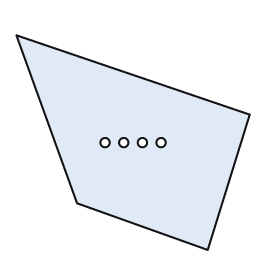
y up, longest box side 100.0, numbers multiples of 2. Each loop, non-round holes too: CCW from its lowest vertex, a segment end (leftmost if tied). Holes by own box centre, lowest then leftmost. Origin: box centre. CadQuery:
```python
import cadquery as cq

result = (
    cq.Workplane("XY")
    .moveTo(32.0, -46.0)
    .lineTo(50.0, 12.0)
    .lineTo(-50.0, 46.0)
    .lineTo(-24.0, -26.0)
    .close()
    .moveTo(-12.0, 0.0)
    .circle(2.0)
    .moveTo(-4.0, 0.0)
    .circle(2.0)
    .moveTo(4.0, 0.0)
    .circle(2.0)
    .moveTo(12.0, 0.0)
    .circle(2.0)
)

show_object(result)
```